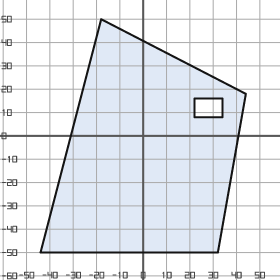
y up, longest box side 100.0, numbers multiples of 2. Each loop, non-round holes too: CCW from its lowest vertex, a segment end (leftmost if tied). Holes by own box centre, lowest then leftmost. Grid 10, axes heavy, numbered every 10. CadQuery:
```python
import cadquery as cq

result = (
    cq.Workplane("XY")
    .moveTo(-44.0, -50.0)
    .lineTo(32.0, -50.0)
    .lineTo(44.0, 18.0)
    .lineTo(-18.0, 50.0)
    .close()
    .moveTo(22.0, 8.0)
    .lineTo(34.0, 8.0)
    .lineTo(34.0, 16.0)
    .lineTo(22.0, 16.0)
    .close()
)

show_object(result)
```